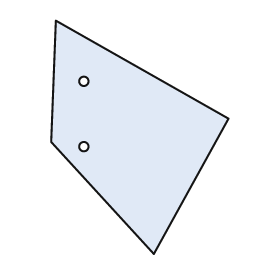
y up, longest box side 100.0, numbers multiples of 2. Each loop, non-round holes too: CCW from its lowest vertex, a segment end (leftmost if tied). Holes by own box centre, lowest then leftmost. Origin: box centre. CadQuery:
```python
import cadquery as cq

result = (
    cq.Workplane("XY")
    .moveTo(6.0, -50.0)
    .lineTo(38.0, 8.0)
    .lineTo(-36.0, 50.0)
    .lineTo(-38.0, -2.0)
    .close()
    .moveTo(-24.0, -4.0)
    .circle(2.0)
    .moveTo(-24.0, 24.0)
    .circle(2.0)
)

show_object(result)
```